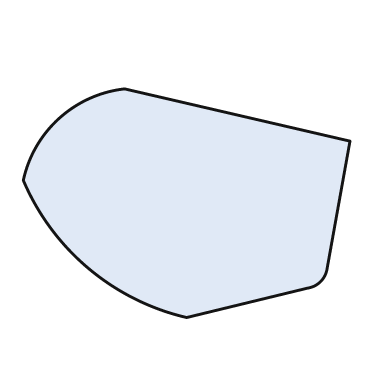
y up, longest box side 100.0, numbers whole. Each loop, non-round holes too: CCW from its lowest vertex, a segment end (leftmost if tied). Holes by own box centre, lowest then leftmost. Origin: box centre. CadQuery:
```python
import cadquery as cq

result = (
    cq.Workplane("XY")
    .moveTo(0.0, -35.0)
    .lineTo(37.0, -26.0)
    .threePointArc((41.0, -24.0), (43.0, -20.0))
    .lineTo(50.0, 19.0)
    .lineTo(-19.0, 35.0)
    .threePointArc((-39.0, 26.0), (-50.0, 7.0))
    .threePointArc((-30.0, -20.0), (0.0, -35.0))
    .close()
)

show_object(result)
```